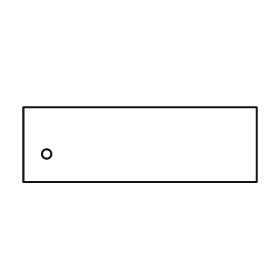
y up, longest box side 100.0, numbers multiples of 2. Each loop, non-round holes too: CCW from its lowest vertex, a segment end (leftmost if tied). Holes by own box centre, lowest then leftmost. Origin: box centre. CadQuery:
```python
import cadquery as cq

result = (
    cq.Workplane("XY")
    .moveTo(-50.0, -16.0)
    .lineTo(50.0, -16.0)
    .lineTo(50.0, 16.0)
    .lineTo(-50.0, 16.0)
    .close()
    .moveTo(-40.0, -4.0)
    .circle(2.0)
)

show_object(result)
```